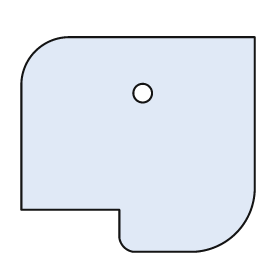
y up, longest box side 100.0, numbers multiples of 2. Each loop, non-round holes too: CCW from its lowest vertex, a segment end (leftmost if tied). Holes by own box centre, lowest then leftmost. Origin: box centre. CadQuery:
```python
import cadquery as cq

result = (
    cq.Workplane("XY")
    .moveTo(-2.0, -46.0)
    .lineTo(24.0, -46.0)
    .threePointArc((42.0, -38.0), (50.0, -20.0))
    .lineTo(50.0, 46.0)
    .lineTo(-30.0, 46.0)
    .threePointArc((-44.0, 40.0), (-50.0, 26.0))
    .lineTo(-50.0, -28.0)
    .lineTo(-8.0, -28.0)
    .lineTo(-8.0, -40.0)
    .threePointArc((-6.0, -44.0), (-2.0, -46.0))
    .close()
    .moveTo(2.0, 22.0)
    .circle(4.0)
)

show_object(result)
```